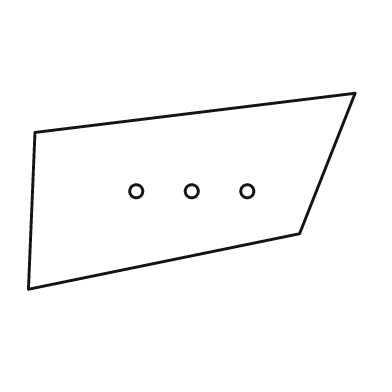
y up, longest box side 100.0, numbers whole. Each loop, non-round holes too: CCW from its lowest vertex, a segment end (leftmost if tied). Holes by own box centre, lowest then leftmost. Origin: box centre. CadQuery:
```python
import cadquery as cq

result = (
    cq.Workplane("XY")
    .moveTo(-50.0, -30.0)
    .lineTo(33.0, -13.0)
    .lineTo(50.0, 30.0)
    .lineTo(-48.0, 18.0)
    .close()
    .moveTo(-17.0, 0.0)
    .circle(2.0)
    .moveTo(0.0, 0.0)
    .circle(2.0)
    .moveTo(17.0, 0.0)
    .circle(2.0)
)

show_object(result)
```